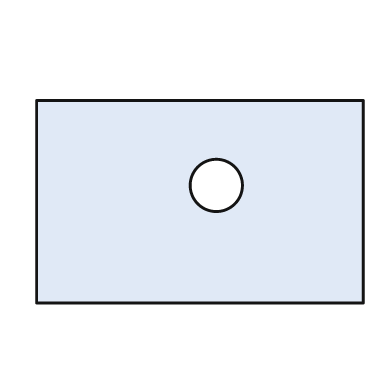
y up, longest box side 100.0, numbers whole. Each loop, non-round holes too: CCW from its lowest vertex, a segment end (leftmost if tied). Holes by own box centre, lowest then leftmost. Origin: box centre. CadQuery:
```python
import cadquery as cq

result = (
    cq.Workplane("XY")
    .moveTo(-50.0, -31.0)
    .lineTo(50.0, -31.0)
    .lineTo(50.0, 31.0)
    .lineTo(-50.0, 31.0)
    .close()
    .moveTo(5.0, 5.0)
    .circle(8.0)
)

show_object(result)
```